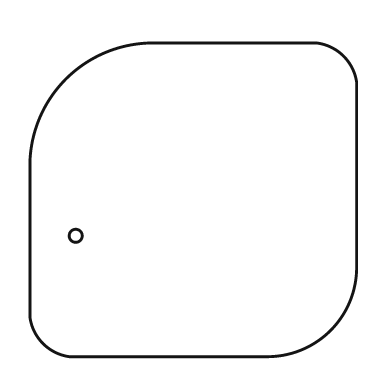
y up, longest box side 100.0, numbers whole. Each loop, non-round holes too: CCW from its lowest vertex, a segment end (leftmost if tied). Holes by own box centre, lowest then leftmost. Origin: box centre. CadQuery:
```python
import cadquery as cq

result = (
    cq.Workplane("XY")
    .moveTo(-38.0, -48.0)
    .lineTo(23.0, -48.0)
    .threePointArc((42.0, -40.0), (50.0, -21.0))
    .lineTo(50.0, 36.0)
    .threePointArc((46.0, 44.0), (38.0, 48.0))
    .lineTo(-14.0, 48.0)
    .threePointArc((-39.0, 37.0), (-50.0, 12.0))
    .lineTo(-50.0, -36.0)
    .threePointArc((-46.0, -44.0), (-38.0, -48.0))
    .close()
    .moveTo(-36.0, -11.0)
    .circle(2.0)
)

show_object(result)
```